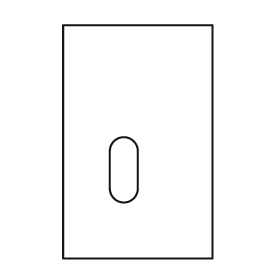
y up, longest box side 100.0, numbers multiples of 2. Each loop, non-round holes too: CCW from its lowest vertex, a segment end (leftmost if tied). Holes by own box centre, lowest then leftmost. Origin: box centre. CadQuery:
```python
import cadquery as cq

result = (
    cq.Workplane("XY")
    .moveTo(-32.0, -50.0)
    .lineTo(32.0, -50.0)
    .lineTo(32.0, 50.0)
    .lineTo(-32.0, 50.0)
    .close()
    .moveTo(-12.0, -20.0)
    .threePointArc((-6.0, -26.0), (0.0, -20.0))
    .lineTo(0.0, -4.0)
    .threePointArc((-6.0, 2.0), (-12.0, -4.0))
    .close()
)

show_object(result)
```